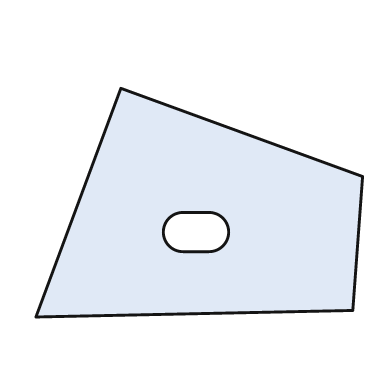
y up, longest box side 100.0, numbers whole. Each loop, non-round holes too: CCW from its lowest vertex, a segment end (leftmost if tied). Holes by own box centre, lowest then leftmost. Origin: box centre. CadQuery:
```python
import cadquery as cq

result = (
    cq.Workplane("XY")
    .moveTo(-50.0, -35.0)
    .lineTo(47.0, -33.0)
    .lineTo(50.0, 8.0)
    .lineTo(-24.0, 35.0)
    .close()
    .moveTo(-5.0, -15.0)
    .lineTo(3.0, -15.0)
    .threePointArc((9.0, -9.0), (3.0, -3.0))
    .lineTo(-5.0, -3.0)
    .threePointArc((-11.0, -9.0), (-5.0, -15.0))
    .close()
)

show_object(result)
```